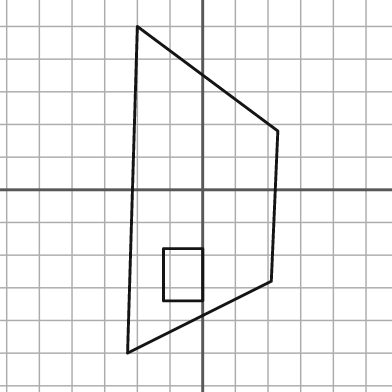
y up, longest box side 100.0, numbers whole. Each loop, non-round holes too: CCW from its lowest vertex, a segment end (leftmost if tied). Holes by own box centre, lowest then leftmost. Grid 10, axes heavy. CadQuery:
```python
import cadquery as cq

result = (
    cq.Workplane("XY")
    .moveTo(-23.0, -50.0)
    .lineTo(21.0, -28.0)
    .lineTo(23.0, 18.0)
    .lineTo(-20.0, 50.0)
    .close()
    .moveTo(-12.0, -34.0)
    .lineTo(0.0, -34.0)
    .lineTo(0.0, -18.0)
    .lineTo(-12.0, -18.0)
    .close()
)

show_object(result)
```